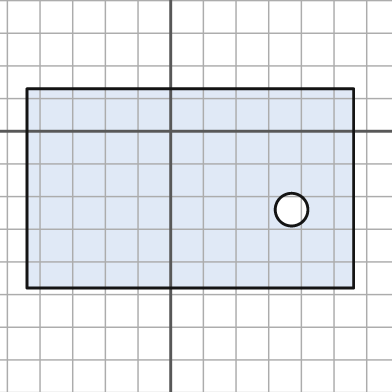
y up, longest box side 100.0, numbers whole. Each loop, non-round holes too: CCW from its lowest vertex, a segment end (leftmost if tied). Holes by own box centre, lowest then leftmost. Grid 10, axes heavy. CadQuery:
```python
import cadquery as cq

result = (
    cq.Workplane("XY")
    .moveTo(-44.0, -48.0)
    .lineTo(56.0, -48.0)
    .lineTo(56.0, 13.0)
    .lineTo(-44.0, 13.0)
    .close()
    .moveTo(37.0, -24.0)
    .circle(5.0)
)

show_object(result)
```